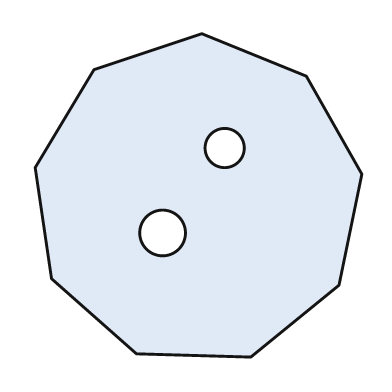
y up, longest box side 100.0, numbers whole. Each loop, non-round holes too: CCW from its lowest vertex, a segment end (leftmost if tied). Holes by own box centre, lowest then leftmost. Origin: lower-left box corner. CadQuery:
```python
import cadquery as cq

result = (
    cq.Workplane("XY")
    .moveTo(66.0, 0.0)
    .lineTo(93.0, 22.0)
    .lineTo(100.0, 56.0)
    .lineTo(83.0, 86.0)
    .lineTo(51.0, 99.0)
    .lineTo(18.0, 88.0)
    .lineTo(0.0, 58.0)
    .lineTo(5.0, 24.0)
    .lineTo(31.0, 1.0)
    .close()
    .moveTo(39.0, 38.0)
    .circle(7.0)
    .moveTo(58.0, 64.0)
    .circle(6.0)
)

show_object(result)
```